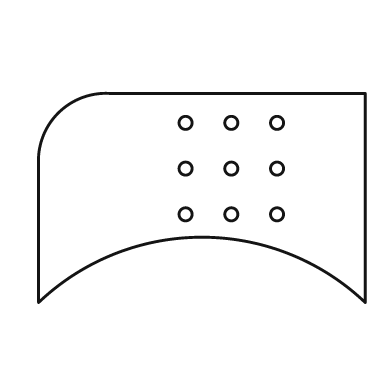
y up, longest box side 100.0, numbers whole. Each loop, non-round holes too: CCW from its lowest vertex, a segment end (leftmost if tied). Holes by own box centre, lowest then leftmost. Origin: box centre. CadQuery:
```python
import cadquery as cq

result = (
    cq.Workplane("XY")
    .moveTo(-50.0, -32.0)
    .threePointArc((0.0, -12.0), (50.0, -32.0))
    .lineTo(50.0, 32.0)
    .lineTo(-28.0, 32.0)
    .threePointArc((-44.0, 26.0), (-50.0, 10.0))
    .close()
    .moveTo(-5.0, -5.0)
    .circle(2.0)
    .moveTo(9.0, -5.0)
    .circle(2.0)
    .moveTo(23.0, -5.0)
    .circle(2.0)
    .moveTo(-5.0, 9.0)
    .circle(2.0)
    .moveTo(9.0, 9.0)
    .circle(2.0)
    .moveTo(23.0, 9.0)
    .circle(2.0)
    .moveTo(-5.0, 23.0)
    .circle(2.0)
    .moveTo(9.0, 23.0)
    .circle(2.0)
    .moveTo(23.0, 23.0)
    .circle(2.0)
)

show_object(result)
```